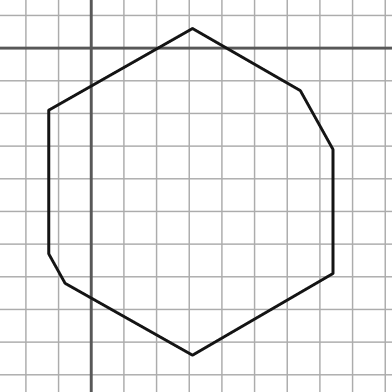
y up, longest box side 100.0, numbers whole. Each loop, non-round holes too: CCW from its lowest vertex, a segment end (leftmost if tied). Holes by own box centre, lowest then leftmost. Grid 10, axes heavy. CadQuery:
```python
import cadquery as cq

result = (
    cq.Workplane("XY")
    .moveTo(31.0, -94.0)
    .lineTo(74.0, -69.0)
    .lineTo(74.0, -31.0)
    .lineTo(64.0, -13.0)
    .lineTo(31.0, 6.0)
    .lineTo(-13.0, -19.0)
    .lineTo(-13.0, -63.0)
    .lineTo(-8.0, -72.0)
    .close()
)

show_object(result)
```